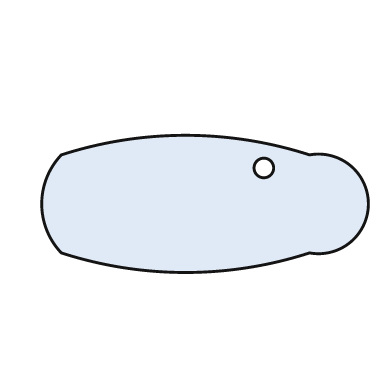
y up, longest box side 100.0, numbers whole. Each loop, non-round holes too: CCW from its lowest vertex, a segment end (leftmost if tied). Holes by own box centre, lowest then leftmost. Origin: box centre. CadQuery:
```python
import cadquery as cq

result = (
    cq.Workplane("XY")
    .moveTo(-44.0, -15.0)
    .threePointArc((-6.0, -21.0), (32.0, -15.0))
    .threePointArc((50.0, 0.0), (32.0, 15.0))
    .threePointArc((-6.0, 21.0), (-44.0, 15.0))
    .threePointArc((-50.0, 0.0), (-44.0, -15.0))
    .close()
    .moveTo(18.0, 11.0)
    .circle(3.0)
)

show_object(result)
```